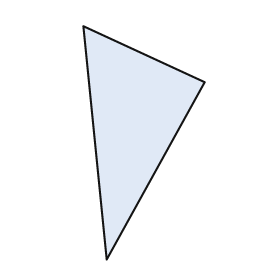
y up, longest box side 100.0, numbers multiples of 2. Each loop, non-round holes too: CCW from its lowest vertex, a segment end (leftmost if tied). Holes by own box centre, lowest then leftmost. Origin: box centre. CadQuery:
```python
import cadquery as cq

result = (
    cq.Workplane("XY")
    .moveTo(-16.0, -50.0)
    .lineTo(26.0, 26.0)
    .lineTo(-26.0, 50.0)
    .close()
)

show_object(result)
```